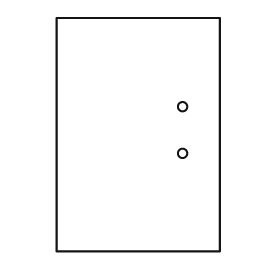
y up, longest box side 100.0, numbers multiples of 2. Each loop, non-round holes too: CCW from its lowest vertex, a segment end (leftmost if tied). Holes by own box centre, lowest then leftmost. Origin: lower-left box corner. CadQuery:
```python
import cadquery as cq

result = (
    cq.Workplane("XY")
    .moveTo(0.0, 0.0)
    .lineTo(70.0, 0.0)
    .lineTo(70.0, 100.0)
    .lineTo(0.0, 100.0)
    .close()
    .moveTo(54.0, 42.0)
    .circle(2.0)
    .moveTo(54.0, 62.0)
    .circle(2.0)
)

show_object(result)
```